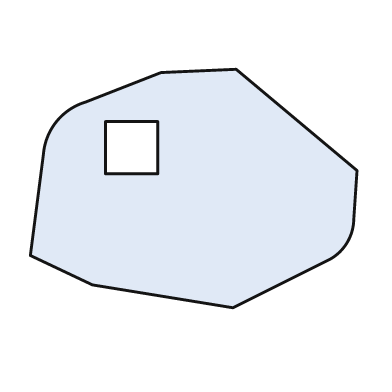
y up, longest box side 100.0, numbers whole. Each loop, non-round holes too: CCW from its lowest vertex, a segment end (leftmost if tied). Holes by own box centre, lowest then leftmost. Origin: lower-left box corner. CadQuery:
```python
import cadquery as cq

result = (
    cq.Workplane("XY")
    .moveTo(62.0, 0.0)
    .lineTo(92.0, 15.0)
    .threePointArc((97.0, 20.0), (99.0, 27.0))
    .lineTo(100.0, 42.0)
    .lineTo(63.0, 73.0)
    .lineTo(40.0, 72.0)
    .lineTo(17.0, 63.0)
    .threePointArc((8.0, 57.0), (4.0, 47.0))
    .lineTo(0.0, 16.0)
    .lineTo(19.0, 7.0)
    .close()
    .moveTo(23.0, 41.0)
    .lineTo(39.0, 41.0)
    .lineTo(39.0, 57.0)
    .lineTo(23.0, 57.0)
    .close()
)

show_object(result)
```